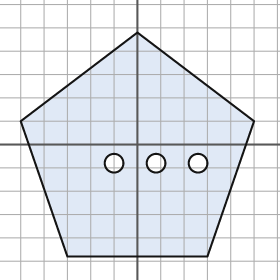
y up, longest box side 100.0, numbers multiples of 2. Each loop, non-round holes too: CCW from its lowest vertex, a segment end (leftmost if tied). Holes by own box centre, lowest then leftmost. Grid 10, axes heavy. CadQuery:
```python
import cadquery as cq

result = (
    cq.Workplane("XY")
    .moveTo(-30.0, -48.0)
    .lineTo(30.0, -48.0)
    .lineTo(50.0, 10.0)
    .lineTo(0.0, 48.0)
    .lineTo(-50.0, 10.0)
    .close()
    .moveTo(-10.0, -8.0)
    .circle(4.0)
    .moveTo(8.0, -8.0)
    .circle(4.0)
    .moveTo(26.0, -8.0)
    .circle(4.0)
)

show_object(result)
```